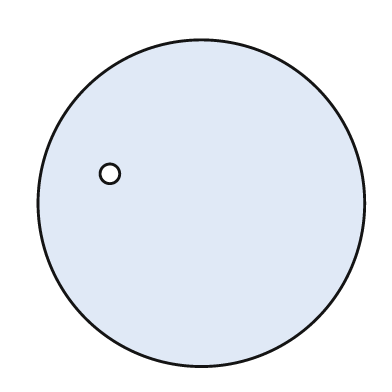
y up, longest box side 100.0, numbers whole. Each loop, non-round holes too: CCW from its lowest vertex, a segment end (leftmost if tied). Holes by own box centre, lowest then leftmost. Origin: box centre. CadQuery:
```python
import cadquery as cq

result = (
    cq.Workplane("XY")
    .moveTo(0.0, 0.0)
    .circle(50.0)
    .moveTo(-28.0, 9.0)
    .circle(3.0)
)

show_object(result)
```